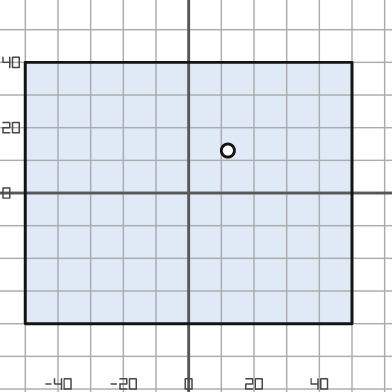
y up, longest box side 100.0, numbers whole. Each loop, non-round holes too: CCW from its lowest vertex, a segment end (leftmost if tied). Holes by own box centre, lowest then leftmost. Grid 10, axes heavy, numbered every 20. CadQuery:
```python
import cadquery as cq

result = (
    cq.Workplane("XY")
    .moveTo(-50.0, -40.0)
    .lineTo(50.0, -40.0)
    .lineTo(50.0, 40.0)
    .lineTo(-50.0, 40.0)
    .close()
    .moveTo(12.0, 13.0)
    .circle(2.0)
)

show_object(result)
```